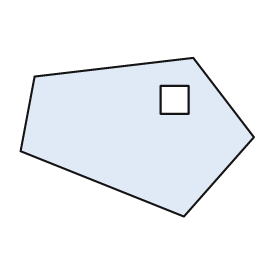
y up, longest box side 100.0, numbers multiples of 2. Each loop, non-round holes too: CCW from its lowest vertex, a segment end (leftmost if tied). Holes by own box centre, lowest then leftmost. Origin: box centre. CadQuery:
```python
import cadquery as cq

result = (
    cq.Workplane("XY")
    .moveTo(20.0, -34.0)
    .lineTo(50.0, 0.0)
    .lineTo(24.0, 34.0)
    .lineTo(-44.0, 26.0)
    .lineTo(-50.0, -6.0)
    .close()
    .moveTo(10.0, 10.0)
    .lineTo(22.0, 10.0)
    .lineTo(22.0, 22.0)
    .lineTo(10.0, 22.0)
    .close()
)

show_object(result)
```